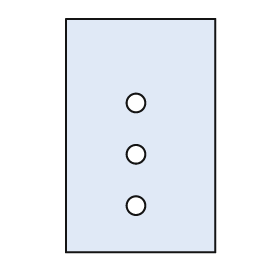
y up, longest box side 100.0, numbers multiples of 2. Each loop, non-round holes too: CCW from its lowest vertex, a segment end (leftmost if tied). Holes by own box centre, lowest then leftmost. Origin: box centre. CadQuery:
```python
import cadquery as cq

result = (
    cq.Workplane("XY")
    .moveTo(-32.0, -50.0)
    .lineTo(32.0, -50.0)
    .lineTo(32.0, 50.0)
    .lineTo(-32.0, 50.0)
    .close()
    .moveTo(-2.0, -30.0)
    .circle(4.0)
    .moveTo(-2.0, -8.0)
    .circle(4.0)
    .moveTo(-2.0, 14.0)
    .circle(4.0)
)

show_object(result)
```